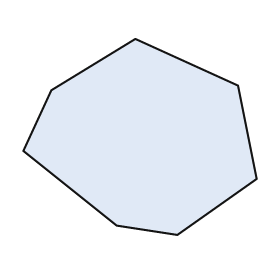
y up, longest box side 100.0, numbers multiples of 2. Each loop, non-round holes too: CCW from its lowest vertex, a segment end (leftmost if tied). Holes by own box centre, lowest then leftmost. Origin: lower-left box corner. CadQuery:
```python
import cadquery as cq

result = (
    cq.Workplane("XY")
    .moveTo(66.0, 0.0)
    .lineTo(100.0, 24.0)
    .lineTo(92.0, 64.0)
    .lineTo(48.0, 84.0)
    .lineTo(12.0, 62.0)
    .lineTo(0.0, 36.0)
    .lineTo(40.0, 4.0)
    .close()
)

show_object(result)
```